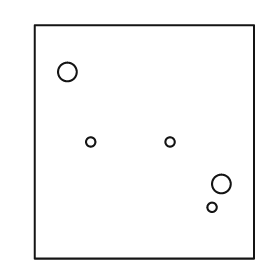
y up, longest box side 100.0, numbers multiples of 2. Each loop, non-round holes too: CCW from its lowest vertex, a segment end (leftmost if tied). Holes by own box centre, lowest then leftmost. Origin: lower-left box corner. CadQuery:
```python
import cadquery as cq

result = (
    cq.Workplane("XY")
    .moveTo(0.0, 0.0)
    .lineTo(94.0, 0.0)
    .lineTo(94.0, 100.0)
    .lineTo(0.0, 100.0)
    .close()
    .moveTo(76.0, 22.0)
    .circle(2.0)
    .moveTo(80.0, 32.0)
    .circle(4.0)
    .moveTo(24.0, 50.0)
    .circle(2.0)
    .moveTo(58.0, 50.0)
    .circle(2.0)
    .moveTo(14.0, 80.0)
    .circle(4.0)
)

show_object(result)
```